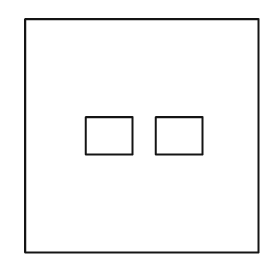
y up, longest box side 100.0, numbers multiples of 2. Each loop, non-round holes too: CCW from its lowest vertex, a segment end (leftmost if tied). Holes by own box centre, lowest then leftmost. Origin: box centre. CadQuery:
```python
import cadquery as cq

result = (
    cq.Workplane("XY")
    .moveTo(-50.0, -50.0)
    .lineTo(50.0, -50.0)
    .lineTo(50.0, 50.0)
    .lineTo(-50.0, 50.0)
    .close()
    .moveTo(-24.0, -8.0)
    .lineTo(-4.0, -8.0)
    .lineTo(-4.0, 8.0)
    .lineTo(-24.0, 8.0)
    .close()
    .moveTo(6.0, -8.0)
    .lineTo(26.0, -8.0)
    .lineTo(26.0, 8.0)
    .lineTo(6.0, 8.0)
    .close()
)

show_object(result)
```